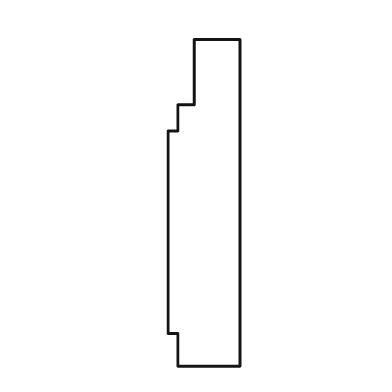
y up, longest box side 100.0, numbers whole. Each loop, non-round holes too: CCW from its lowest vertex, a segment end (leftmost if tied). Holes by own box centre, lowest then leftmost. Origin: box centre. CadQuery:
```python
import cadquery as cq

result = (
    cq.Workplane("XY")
    .moveTo(-8.0, -50.0)
    .lineTo(11.0, -50.0)
    .lineTo(11.0, 50.0)
    .lineTo(-3.0, 50.0)
    .lineTo(-3.0, 30.0)
    .lineTo(-8.0, 30.0)
    .lineTo(-8.0, 22.0)
    .lineTo(-11.0, 22.0)
    .lineTo(-11.0, -40.0)
    .lineTo(-8.0, -40.0)
    .close()
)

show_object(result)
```